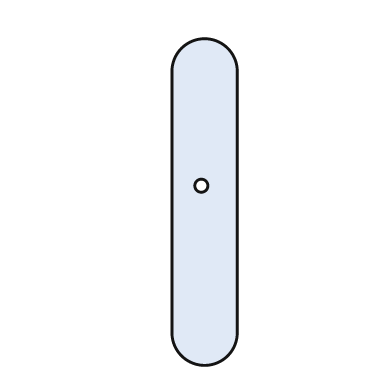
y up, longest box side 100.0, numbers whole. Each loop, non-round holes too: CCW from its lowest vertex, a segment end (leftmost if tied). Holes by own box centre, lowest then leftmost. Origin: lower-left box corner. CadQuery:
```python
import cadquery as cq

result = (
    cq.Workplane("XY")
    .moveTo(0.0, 10.0)
    .threePointArc((10.0, 0.0), (20.0, 10.0))
    .lineTo(20.0, 90.0)
    .threePointArc((10.0, 100.0), (0.0, 90.0))
    .close()
    .moveTo(9.0, 55.0)
    .circle(2.0)
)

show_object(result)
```